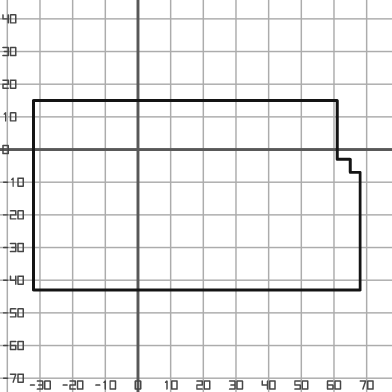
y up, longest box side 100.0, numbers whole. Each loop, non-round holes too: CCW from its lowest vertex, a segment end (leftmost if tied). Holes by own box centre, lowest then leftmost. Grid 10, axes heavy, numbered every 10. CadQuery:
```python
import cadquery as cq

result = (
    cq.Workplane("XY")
    .moveTo(-32.0, -43.0)
    .lineTo(68.0, -43.0)
    .lineTo(68.0, -7.0)
    .lineTo(65.0, -7.0)
    .lineTo(65.0, -3.0)
    .lineTo(61.0, -3.0)
    .lineTo(61.0, 15.0)
    .lineTo(-32.0, 15.0)
    .close()
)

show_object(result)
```